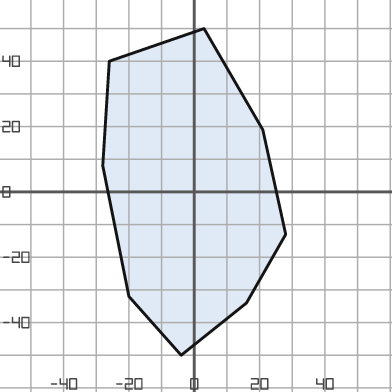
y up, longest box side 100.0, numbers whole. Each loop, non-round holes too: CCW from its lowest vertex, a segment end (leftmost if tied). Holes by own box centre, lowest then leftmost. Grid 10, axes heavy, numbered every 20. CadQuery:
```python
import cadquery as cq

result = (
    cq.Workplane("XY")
    .moveTo(-4.0, -50.0)
    .lineTo(16.0, -34.0)
    .lineTo(28.0, -13.0)
    .lineTo(21.0, 19.0)
    .lineTo(3.0, 50.0)
    .lineTo(-26.0, 40.0)
    .lineTo(-28.0, 8.0)
    .lineTo(-20.0, -32.0)
    .close()
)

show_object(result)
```